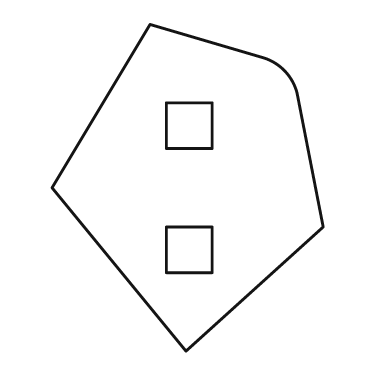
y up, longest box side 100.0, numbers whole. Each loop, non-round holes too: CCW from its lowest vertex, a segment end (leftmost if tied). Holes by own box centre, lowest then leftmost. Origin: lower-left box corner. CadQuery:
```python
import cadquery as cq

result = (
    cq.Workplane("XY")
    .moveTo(41.0, 0.0)
    .lineTo(83.0, 38.0)
    .lineTo(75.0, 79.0)
    .threePointArc((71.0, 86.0), (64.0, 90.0))
    .lineTo(30.0, 100.0)
    .lineTo(0.0, 50.0)
    .close()
    .moveTo(35.0, 24.0)
    .lineTo(49.0, 24.0)
    .lineTo(49.0, 38.0)
    .lineTo(35.0, 38.0)
    .close()
    .moveTo(35.0, 62.0)
    .lineTo(49.0, 62.0)
    .lineTo(49.0, 76.0)
    .lineTo(35.0, 76.0)
    .close()
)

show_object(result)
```